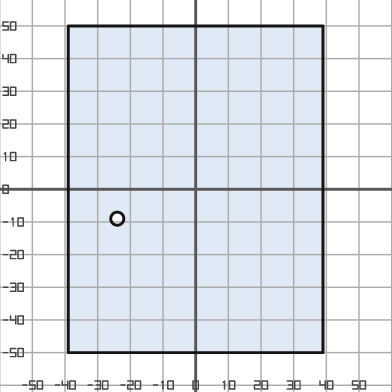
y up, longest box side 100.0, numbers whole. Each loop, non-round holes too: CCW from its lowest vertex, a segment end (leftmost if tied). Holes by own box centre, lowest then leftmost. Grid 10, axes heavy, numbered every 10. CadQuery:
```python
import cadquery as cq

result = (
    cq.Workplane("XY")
    .moveTo(-39.0, -50.0)
    .lineTo(39.0, -50.0)
    .lineTo(39.0, 50.0)
    .lineTo(-39.0, 50.0)
    .close()
    .moveTo(-24.0, -9.0)
    .circle(2.0)
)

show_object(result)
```